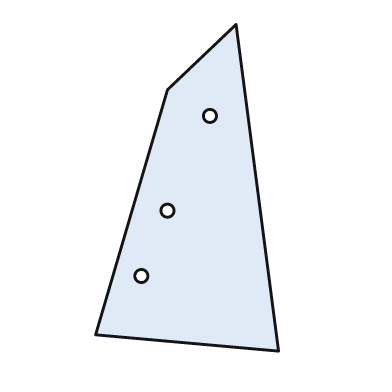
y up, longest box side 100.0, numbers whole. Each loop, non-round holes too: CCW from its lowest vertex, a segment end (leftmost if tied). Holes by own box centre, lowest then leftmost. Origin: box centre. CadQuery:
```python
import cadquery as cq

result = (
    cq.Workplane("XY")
    .moveTo(28.0, -50.0)
    .lineTo(15.0, 50.0)
    .lineTo(-6.0, 30.0)
    .lineTo(-28.0, -45.0)
    .close()
    .moveTo(-14.0, -27.0)
    .circle(2.0)
    .moveTo(-6.0, -7.0)
    .circle(2.0)
    .moveTo(7.0, 22.0)
    .circle(2.0)
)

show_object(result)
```